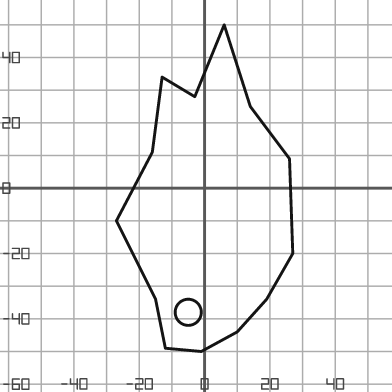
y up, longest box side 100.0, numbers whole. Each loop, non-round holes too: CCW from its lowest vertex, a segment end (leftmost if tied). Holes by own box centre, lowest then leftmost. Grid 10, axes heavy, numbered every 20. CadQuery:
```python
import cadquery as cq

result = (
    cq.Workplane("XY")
    .moveTo(-1.0, -50.0)
    .lineTo(10.0, -44.0)
    .lineTo(19.0, -34.0)
    .lineTo(27.0, -20.0)
    .lineTo(26.0, 9.0)
    .lineTo(14.0, 25.0)
    .lineTo(6.0, 50.0)
    .lineTo(-3.0, 28.0)
    .lineTo(-13.0, 34.0)
    .lineTo(-16.0, 11.0)
    .lineTo(-27.0, -10.0)
    .lineTo(-15.0, -34.0)
    .lineTo(-12.0, -49.0)
    .close()
    .moveTo(-5.0, -38.0)
    .circle(4.0)
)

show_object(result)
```